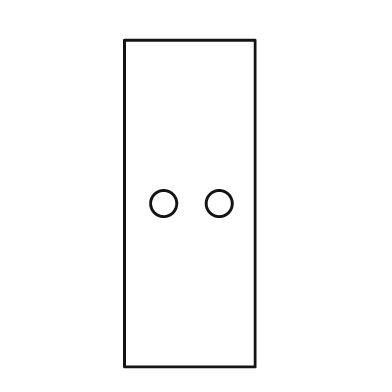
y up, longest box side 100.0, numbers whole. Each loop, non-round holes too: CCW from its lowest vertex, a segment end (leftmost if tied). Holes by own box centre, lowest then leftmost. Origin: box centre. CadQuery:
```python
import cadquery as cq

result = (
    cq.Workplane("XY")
    .moveTo(-20.0, -50.0)
    .lineTo(20.0, -50.0)
    .lineTo(20.0, 50.0)
    .lineTo(-20.0, 50.0)
    .close()
    .moveTo(-8.0, 0.0)
    .circle(4.0)
    .moveTo(9.0, 0.0)
    .circle(4.0)
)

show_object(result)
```